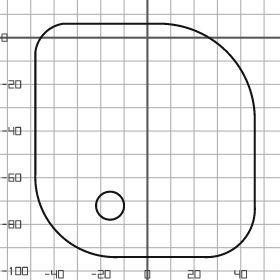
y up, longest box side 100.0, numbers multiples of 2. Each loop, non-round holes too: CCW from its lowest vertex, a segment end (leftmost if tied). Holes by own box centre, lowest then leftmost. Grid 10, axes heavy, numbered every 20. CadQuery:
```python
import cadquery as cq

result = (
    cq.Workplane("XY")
    .moveTo(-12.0, -94.0)
    .lineTo(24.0, -94.0)
    .threePointArc((40.0, -88.0), (46.0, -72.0))
    .lineTo(46.0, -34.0)
    .threePointArc((34.0, -6.0), (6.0, 6.0))
    .lineTo(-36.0, 6.0)
    .threePointArc((-44.0, 2.0), (-48.0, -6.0))
    .lineTo(-48.0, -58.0)
    .threePointArc((-38.0, -84.0), (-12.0, -94.0))
    .close()
    .moveTo(-16.0, -72.0)
    .circle(6.0)
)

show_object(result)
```